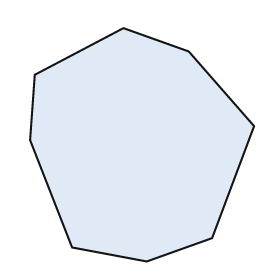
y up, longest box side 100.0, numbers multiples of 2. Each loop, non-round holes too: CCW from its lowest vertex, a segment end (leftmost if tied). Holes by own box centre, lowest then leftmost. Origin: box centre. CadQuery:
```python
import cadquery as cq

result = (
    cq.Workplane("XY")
    .moveTo(2.0, -50.0)
    .lineTo(30.0, -40.0)
    .lineTo(48.0, 8.0)
    .lineTo(20.0, 40.0)
    .lineTo(-8.0, 50.0)
    .lineTo(-46.0, 30.0)
    .lineTo(-48.0, 2.0)
    .lineTo(-30.0, -44.0)
    .close()
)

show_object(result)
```